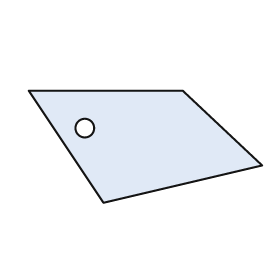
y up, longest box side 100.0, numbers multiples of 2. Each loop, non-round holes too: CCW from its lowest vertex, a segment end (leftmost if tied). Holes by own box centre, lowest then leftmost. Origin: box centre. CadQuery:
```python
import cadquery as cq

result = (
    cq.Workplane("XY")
    .moveTo(-18.0, -24.0)
    .lineTo(50.0, -8.0)
    .lineTo(16.0, 24.0)
    .lineTo(-50.0, 24.0)
    .close()
    .moveTo(-26.0, 8.0)
    .circle(4.0)
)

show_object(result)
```